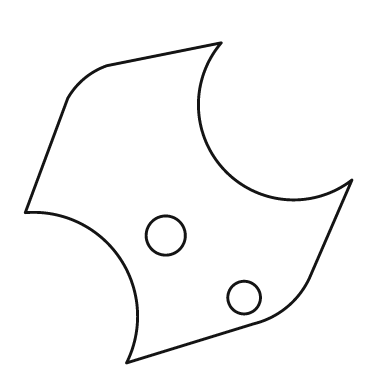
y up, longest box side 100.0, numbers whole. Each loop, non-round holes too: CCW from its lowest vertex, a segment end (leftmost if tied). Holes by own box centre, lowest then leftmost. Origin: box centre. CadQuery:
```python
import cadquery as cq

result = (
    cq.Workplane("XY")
    .moveTo(-19.0, -49.0)
    .lineTo(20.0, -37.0)
    .threePointArc((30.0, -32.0), (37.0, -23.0))
    .lineTo(50.0, 7.0)
    .threePointArc((11.0, 10.0), (10.0, 49.0))
    .lineTo(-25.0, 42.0)
    .threePointArc((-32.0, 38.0), (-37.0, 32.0))
    .lineTo(-50.0, -3.0)
    .threePointArc((-21.0, -17.0), (-19.0, -49.0))
    .close()
    .moveTo(17.0, -29.0)
    .circle(5.0)
    .moveTo(-7.0, -10.0)
    .circle(6.0)
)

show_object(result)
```